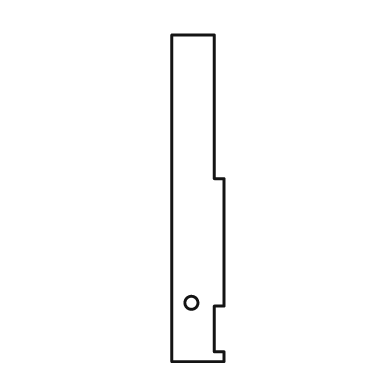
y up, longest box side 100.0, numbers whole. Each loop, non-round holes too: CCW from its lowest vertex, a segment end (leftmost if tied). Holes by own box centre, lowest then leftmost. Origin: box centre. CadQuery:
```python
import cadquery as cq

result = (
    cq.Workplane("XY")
    .moveTo(-8.0, -50.0)
    .lineTo(8.0, -50.0)
    .lineTo(8.0, -47.0)
    .lineTo(5.0, -47.0)
    .lineTo(5.0, -33.0)
    .lineTo(8.0, -33.0)
    .lineTo(8.0, 6.0)
    .lineTo(5.0, 6.0)
    .lineTo(5.0, 50.0)
    .lineTo(-8.0, 50.0)
    .close()
    .moveTo(-2.0, -32.0)
    .circle(2.0)
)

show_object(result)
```